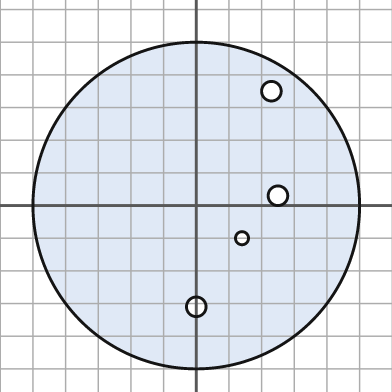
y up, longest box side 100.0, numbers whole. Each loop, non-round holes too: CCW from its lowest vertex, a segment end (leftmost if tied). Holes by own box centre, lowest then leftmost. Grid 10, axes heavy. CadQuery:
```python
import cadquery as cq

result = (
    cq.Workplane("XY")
    .moveTo(0.0, 0.0)
    .circle(50.0)
    .moveTo(0.0, -31.0)
    .circle(3.0)
    .moveTo(14.0, -10.0)
    .circle(2.0)
    .moveTo(25.0, 3.0)
    .circle(3.0)
    .moveTo(23.0, 35.0)
    .circle(3.0)
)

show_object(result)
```